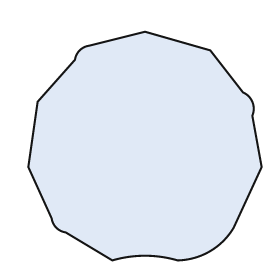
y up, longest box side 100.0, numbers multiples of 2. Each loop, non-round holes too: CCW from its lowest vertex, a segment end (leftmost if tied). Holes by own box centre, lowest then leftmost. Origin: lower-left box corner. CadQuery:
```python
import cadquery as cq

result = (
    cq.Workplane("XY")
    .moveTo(36.0, 0.0)
    .threePointArc((50.0, 2.0), (64.0, 0.0))
    .threePointArc((78.0, 4.0), (88.0, 14.0))
    .lineTo(100.0, 40.0)
    .lineTo(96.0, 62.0)
    .threePointArc((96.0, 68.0), (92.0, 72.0))
    .lineTo(78.0, 90.0)
    .lineTo(50.0, 98.0)
    .lineTo(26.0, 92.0)
    .threePointArc((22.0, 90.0), (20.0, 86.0))
    .lineTo(4.0, 68.0)
    .lineTo(0.0, 40.0)
    .lineTo(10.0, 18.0)
    .threePointArc((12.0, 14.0), (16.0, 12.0))
    .close()
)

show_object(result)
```